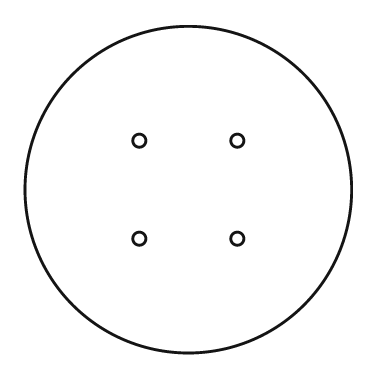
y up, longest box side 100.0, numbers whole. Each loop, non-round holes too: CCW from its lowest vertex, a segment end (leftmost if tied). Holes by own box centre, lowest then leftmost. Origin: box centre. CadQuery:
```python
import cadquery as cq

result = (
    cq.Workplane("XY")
    .moveTo(0.0, 0.0)
    .circle(50.0)
    .moveTo(-15.0, -15.0)
    .circle(2.0)
    .moveTo(15.0, -15.0)
    .circle(2.0)
    .moveTo(-15.0, 15.0)
    .circle(2.0)
    .moveTo(15.0, 15.0)
    .circle(2.0)
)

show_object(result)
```